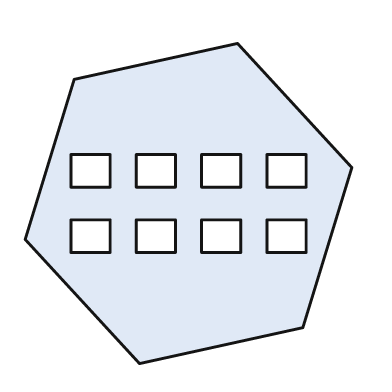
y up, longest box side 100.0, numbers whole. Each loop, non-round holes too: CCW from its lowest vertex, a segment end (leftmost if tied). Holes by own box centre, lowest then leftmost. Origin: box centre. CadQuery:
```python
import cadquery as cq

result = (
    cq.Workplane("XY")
    .moveTo(-15.0, -49.0)
    .lineTo(35.0, -38.0)
    .lineTo(50.0, 11.0)
    .lineTo(15.0, 49.0)
    .lineTo(-35.0, 38.0)
    .lineTo(-50.0, -11.0)
    .close()
    .moveTo(-36.0, -15.0)
    .lineTo(-24.0, -15.0)
    .lineTo(-24.0, -5.0)
    .lineTo(-36.0, -5.0)
    .close()
    .moveTo(-16.0, -15.0)
    .lineTo(-4.0, -15.0)
    .lineTo(-4.0, -5.0)
    .lineTo(-16.0, -5.0)
    .close()
    .moveTo(4.0, -15.0)
    .lineTo(16.0, -15.0)
    .lineTo(16.0, -5.0)
    .lineTo(4.0, -5.0)
    .close()
    .moveTo(24.0, -15.0)
    .lineTo(36.0, -15.0)
    .lineTo(36.0, -5.0)
    .lineTo(24.0, -5.0)
    .close()
    .moveTo(-36.0, 5.0)
    .lineTo(-24.0, 5.0)
    .lineTo(-24.0, 15.0)
    .lineTo(-36.0, 15.0)
    .close()
    .moveTo(-16.0, 5.0)
    .lineTo(-4.0, 5.0)
    .lineTo(-4.0, 15.0)
    .lineTo(-16.0, 15.0)
    .close()
    .moveTo(4.0, 5.0)
    .lineTo(16.0, 5.0)
    .lineTo(16.0, 15.0)
    .lineTo(4.0, 15.0)
    .close()
    .moveTo(24.0, 5.0)
    .lineTo(36.0, 5.0)
    .lineTo(36.0, 15.0)
    .lineTo(24.0, 15.0)
    .close()
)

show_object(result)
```